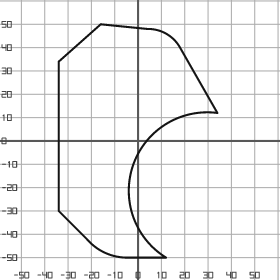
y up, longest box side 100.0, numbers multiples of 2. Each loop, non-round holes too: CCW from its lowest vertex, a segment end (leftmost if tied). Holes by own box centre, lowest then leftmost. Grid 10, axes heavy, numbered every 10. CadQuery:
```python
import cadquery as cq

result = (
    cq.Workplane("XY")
    .moveTo(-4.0, -50.0)
    .lineTo(12.0, -50.0)
    .threePointArc((-2.0, -10.0), (34.0, 12.0))
    .lineTo(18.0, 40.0)
    .threePointArc((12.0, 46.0), (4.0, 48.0))
    .lineTo(-16.0, 50.0)
    .lineTo(-34.0, 34.0)
    .lineTo(-34.0, -30.0)
    .lineTo(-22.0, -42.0)
    .threePointArc((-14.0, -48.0), (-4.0, -50.0))
    .close()
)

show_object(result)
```